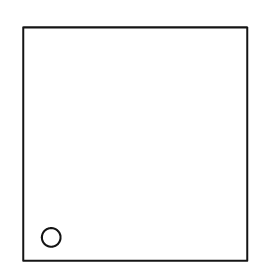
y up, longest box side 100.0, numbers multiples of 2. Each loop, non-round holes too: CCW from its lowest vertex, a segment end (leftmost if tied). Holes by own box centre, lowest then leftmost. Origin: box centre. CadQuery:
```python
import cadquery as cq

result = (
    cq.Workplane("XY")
    .moveTo(-48.0, -50.0)
    .lineTo(48.0, -50.0)
    .lineTo(48.0, 50.0)
    .lineTo(-48.0, 50.0)
    .close()
    .moveTo(-36.0, -40.0)
    .circle(4.0)
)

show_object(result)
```